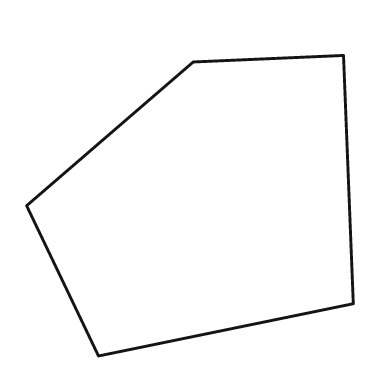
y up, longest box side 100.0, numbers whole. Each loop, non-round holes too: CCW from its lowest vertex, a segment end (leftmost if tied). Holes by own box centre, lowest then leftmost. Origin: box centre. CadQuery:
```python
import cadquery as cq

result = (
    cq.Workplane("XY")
    .moveTo(-28.0, -46.0)
    .lineTo(50.0, -30.0)
    .lineTo(47.0, 46.0)
    .lineTo(1.0, 44.0)
    .lineTo(-50.0, 0.0)
    .close()
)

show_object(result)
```